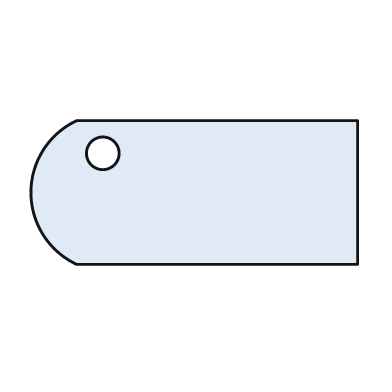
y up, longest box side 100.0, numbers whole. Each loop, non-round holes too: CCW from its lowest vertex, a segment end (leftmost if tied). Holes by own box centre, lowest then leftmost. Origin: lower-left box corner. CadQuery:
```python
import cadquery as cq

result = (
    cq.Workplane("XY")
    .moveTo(14.0, 0.0)
    .lineTo(100.0, 0.0)
    .lineTo(100.0, 44.0)
    .lineTo(14.0, 44.0)
    .threePointArc((0.0, 22.0), (14.0, 0.0))
    .close()
    .moveTo(22.0, 34.0)
    .circle(5.0)
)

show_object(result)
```